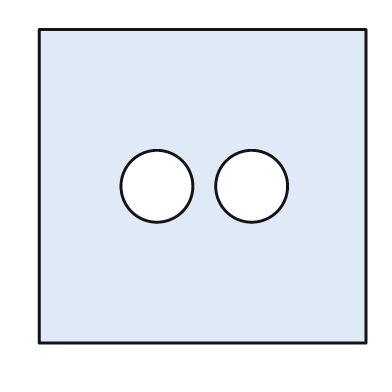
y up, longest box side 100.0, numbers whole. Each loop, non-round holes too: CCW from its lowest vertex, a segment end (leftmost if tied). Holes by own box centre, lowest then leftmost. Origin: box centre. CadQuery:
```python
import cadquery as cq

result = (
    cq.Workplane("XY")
    .moveTo(-50.0, -48.0)
    .lineTo(50.0, -48.0)
    .lineTo(50.0, 48.0)
    .lineTo(-50.0, 48.0)
    .close()
    .moveTo(-14.0, 0.0)
    .circle(11.0)
    .moveTo(15.0, 0.0)
    .circle(11.0)
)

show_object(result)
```